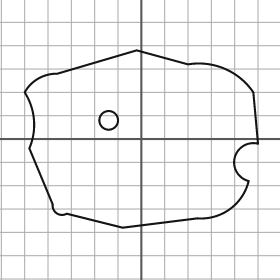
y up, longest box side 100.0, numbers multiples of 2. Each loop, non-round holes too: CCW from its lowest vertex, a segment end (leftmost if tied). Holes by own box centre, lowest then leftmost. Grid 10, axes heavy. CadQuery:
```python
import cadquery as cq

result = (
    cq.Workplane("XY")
    .moveTo(-8.0, -38.0)
    .lineTo(24.0, -34.0)
    .threePointArc((38.0, -30.0), (46.0, -18.0))
    .threePointArc((40.0, -8.0), (50.0, -2.0))
    .lineTo(48.0, 20.0)
    .threePointArc((36.0, 30.0), (20.0, 32.0))
    .lineTo(-2.0, 38.0)
    .lineTo(-36.0, 28.0)
    .threePointArc((-44.0, 26.0), (-50.0, 20.0))
    .threePointArc((-46.0, 8.0), (-48.0, -4.0))
    .lineTo(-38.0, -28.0)
    .threePointArc((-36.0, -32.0), (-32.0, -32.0))
    .close()
    .moveTo(-14.0, 8.0)
    .circle(4.0)
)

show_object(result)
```